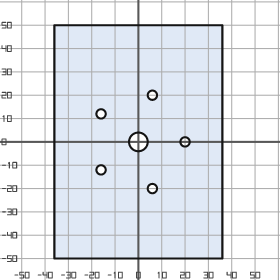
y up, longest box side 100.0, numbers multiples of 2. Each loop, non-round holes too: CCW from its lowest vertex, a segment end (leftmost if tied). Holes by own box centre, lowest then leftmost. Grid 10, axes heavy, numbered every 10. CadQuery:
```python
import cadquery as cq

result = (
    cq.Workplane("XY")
    .moveTo(-36.0, -50.0)
    .lineTo(36.0, -50.0)
    .lineTo(36.0, 50.0)
    .lineTo(-36.0, 50.0)
    .close()
    .moveTo(6.0, -20.0)
    .circle(2.0)
    .moveTo(-16.0, -12.0)
    .circle(2.0)
    .moveTo(0.0, 0.0)
    .circle(4.0)
    .moveTo(20.0, 0.0)
    .circle(2.0)
    .moveTo(-16.0, 12.0)
    .circle(2.0)
    .moveTo(6.0, 20.0)
    .circle(2.0)
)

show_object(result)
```